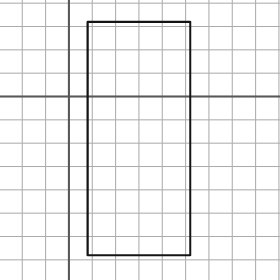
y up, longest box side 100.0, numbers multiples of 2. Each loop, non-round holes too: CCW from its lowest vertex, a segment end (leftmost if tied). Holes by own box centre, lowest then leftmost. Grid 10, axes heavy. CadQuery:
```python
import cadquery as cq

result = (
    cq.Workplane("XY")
    .moveTo(8.0, -68.0)
    .lineTo(52.0, -68.0)
    .lineTo(52.0, 32.0)
    .lineTo(8.0, 32.0)
    .close()
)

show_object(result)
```